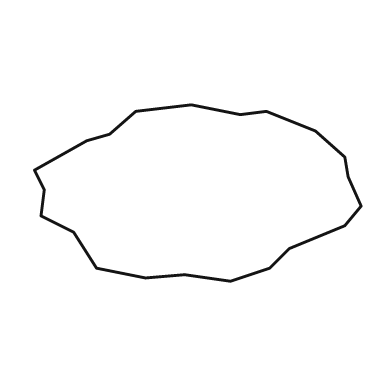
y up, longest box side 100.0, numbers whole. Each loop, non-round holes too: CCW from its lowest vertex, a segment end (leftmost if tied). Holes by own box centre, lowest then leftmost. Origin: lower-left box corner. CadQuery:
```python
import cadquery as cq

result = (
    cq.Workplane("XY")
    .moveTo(60.0, 0.0)
    .lineTo(72.0, 4.0)
    .lineTo(78.0, 10.0)
    .lineTo(95.0, 17.0)
    .lineTo(100.0, 23.0)
    .lineTo(96.0, 32.0)
    .lineTo(95.0, 38.0)
    .lineTo(86.0, 46.0)
    .lineTo(71.0, 52.0)
    .lineTo(63.0, 51.0)
    .lineTo(48.0, 54.0)
    .lineTo(31.0, 52.0)
    .lineTo(23.0, 45.0)
    .lineTo(16.0, 43.0)
    .lineTo(0.0, 34.0)
    .lineTo(3.0, 28.0)
    .lineTo(2.0, 20.0)
    .lineTo(12.0, 15.0)
    .lineTo(19.0, 4.0)
    .lineTo(34.0, 1.0)
    .lineTo(46.0, 2.0)
    .close()
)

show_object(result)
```